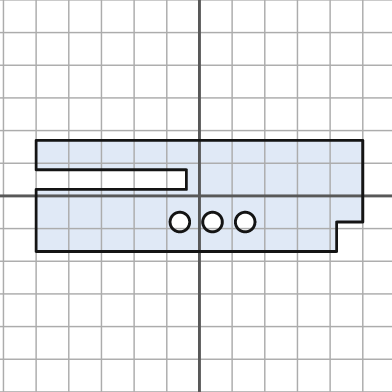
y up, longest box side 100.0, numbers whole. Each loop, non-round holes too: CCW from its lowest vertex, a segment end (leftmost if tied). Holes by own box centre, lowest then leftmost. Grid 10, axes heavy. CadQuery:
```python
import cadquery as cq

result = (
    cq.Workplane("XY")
    .moveTo(-50.0, -17.0)
    .lineTo(42.0, -17.0)
    .lineTo(42.0, -8.0)
    .lineTo(50.0, -8.0)
    .lineTo(50.0, 17.0)
    .lineTo(-50.0, 17.0)
    .lineTo(-50.0, 8.0)
    .lineTo(-4.0, 8.0)
    .lineTo(-4.0, 2.0)
    .lineTo(-50.0, 2.0)
    .close()
    .moveTo(-6.0, -8.0)
    .circle(3.0)
    .moveTo(4.0, -8.0)
    .circle(3.0)
    .moveTo(14.0, -8.0)
    .circle(3.0)
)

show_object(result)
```